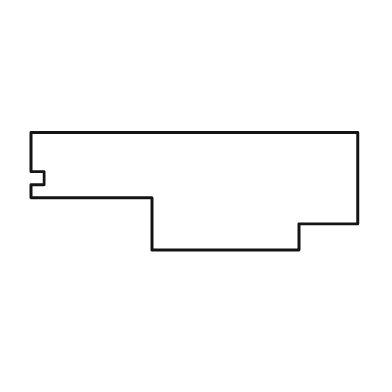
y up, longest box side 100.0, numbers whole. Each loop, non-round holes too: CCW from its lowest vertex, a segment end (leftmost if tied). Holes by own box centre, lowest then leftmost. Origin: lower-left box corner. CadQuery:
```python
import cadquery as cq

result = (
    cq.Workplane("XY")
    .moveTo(37.0, 0.0)
    .lineTo(82.0, 0.0)
    .lineTo(82.0, 8.0)
    .lineTo(100.0, 8.0)
    .lineTo(100.0, 36.0)
    .lineTo(0.0, 36.0)
    .lineTo(0.0, 24.0)
    .lineTo(4.0, 24.0)
    .lineTo(4.0, 20.0)
    .lineTo(0.0, 20.0)
    .lineTo(0.0, 16.0)
    .lineTo(37.0, 16.0)
    .close()
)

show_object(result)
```